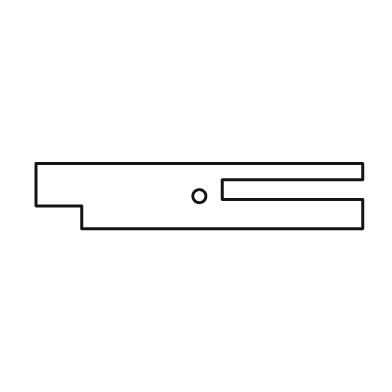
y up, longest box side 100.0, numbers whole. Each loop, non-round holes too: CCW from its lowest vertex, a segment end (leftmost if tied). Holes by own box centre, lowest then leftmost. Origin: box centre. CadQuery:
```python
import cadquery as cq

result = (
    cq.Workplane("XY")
    .moveTo(-36.0, -10.0)
    .lineTo(50.0, -10.0)
    .lineTo(50.0, -1.0)
    .lineTo(7.0, -1.0)
    .lineTo(7.0, 5.0)
    .lineTo(50.0, 5.0)
    .lineTo(50.0, 10.0)
    .lineTo(-50.0, 10.0)
    .lineTo(-50.0, -3.0)
    .lineTo(-36.0, -3.0)
    .close()
    .moveTo(0.0, 0.0)
    .circle(2.0)
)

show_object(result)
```